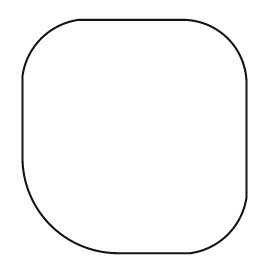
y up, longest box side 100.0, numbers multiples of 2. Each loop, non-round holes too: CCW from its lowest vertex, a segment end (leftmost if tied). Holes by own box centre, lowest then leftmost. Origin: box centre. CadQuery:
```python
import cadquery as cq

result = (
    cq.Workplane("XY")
    .moveTo(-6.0, -50.0)
    .lineTo(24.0, -50.0)
    .threePointArc((40.0, -42.0), (48.0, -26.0))
    .lineTo(48.0, 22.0)
    .threePointArc((40.0, 42.0), (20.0, 50.0))
    .lineTo(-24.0, 50.0)
    .threePointArc((-40.0, 42.0), (-48.0, 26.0))
    .lineTo(-48.0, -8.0)
    .threePointArc((-36.0, -38.0), (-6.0, -50.0))
    .close()
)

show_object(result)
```